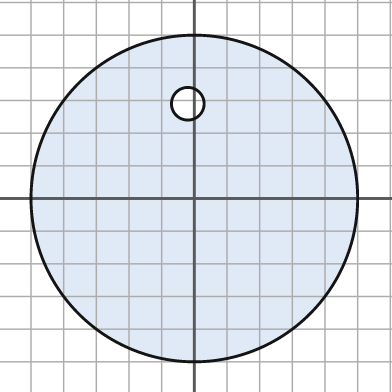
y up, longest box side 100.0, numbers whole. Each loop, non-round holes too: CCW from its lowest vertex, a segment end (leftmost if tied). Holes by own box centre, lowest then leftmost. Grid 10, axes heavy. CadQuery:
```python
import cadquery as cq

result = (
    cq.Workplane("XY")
    .moveTo(0.0, 0.0)
    .circle(50.0)
    .moveTo(-2.0, 29.0)
    .circle(5.0)
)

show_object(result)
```